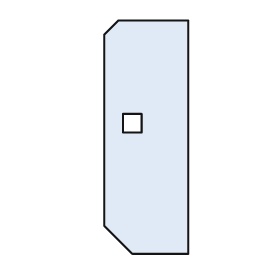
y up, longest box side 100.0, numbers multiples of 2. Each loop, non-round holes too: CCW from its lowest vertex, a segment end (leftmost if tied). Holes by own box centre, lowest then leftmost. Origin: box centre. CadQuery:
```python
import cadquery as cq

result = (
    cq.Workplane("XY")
    .moveTo(-6.0, -50.0)
    .lineTo(18.0, -50.0)
    .lineTo(18.0, 50.0)
    .lineTo(-12.0, 50.0)
    .lineTo(-18.0, 44.0)
    .lineTo(-18.0, -38.0)
    .close()
    .moveTo(-10.0, 2.0)
    .lineTo(-2.0, 2.0)
    .lineTo(-2.0, 10.0)
    .lineTo(-10.0, 10.0)
    .close()
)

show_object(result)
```